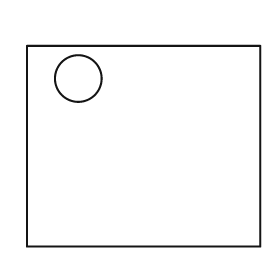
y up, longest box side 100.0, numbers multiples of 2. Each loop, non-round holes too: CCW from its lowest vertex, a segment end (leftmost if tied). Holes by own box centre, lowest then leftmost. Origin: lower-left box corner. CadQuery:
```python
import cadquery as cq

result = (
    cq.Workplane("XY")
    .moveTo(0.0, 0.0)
    .lineTo(100.0, 0.0)
    .lineTo(100.0, 86.0)
    .lineTo(0.0, 86.0)
    .close()
    .moveTo(22.0, 72.0)
    .circle(10.0)
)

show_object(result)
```